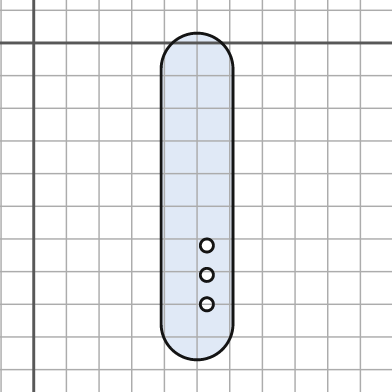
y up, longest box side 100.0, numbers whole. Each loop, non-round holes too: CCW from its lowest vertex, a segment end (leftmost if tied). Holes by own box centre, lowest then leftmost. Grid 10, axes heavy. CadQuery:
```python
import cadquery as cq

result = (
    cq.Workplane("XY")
    .moveTo(39.0, -86.0)
    .threePointArc((50.0, -97.0), (61.0, -86.0))
    .lineTo(61.0, -8.0)
    .threePointArc((50.0, 3.0), (39.0, -8.0))
    .close()
    .moveTo(53.0, -80.0)
    .circle(2.0)
    .moveTo(53.0, -71.0)
    .circle(2.0)
    .moveTo(53.0, -62.0)
    .circle(2.0)
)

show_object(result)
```